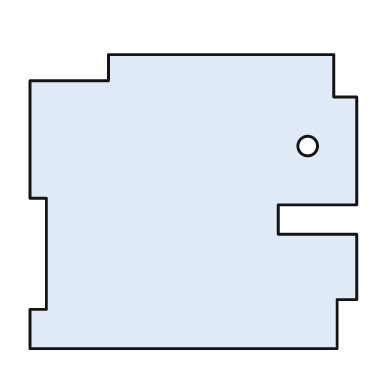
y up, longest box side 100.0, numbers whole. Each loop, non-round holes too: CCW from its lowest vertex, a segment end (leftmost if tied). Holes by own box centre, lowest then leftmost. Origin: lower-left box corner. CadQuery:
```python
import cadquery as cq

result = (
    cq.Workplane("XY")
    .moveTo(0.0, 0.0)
    .lineTo(94.0, 0.0)
    .lineTo(94.0, 15.0)
    .lineTo(100.0, 15.0)
    .lineTo(100.0, 35.0)
    .lineTo(76.0, 35.0)
    .lineTo(76.0, 44.0)
    .lineTo(100.0, 44.0)
    .lineTo(100.0, 77.0)
    .lineTo(93.0, 77.0)
    .lineTo(93.0, 90.0)
    .lineTo(24.0, 90.0)
    .lineTo(24.0, 82.0)
    .lineTo(0.0, 82.0)
    .lineTo(0.0, 46.0)
    .lineTo(5.0, 46.0)
    .lineTo(5.0, 12.0)
    .lineTo(0.0, 12.0)
    .close()
    .moveTo(85.0, 62.0)
    .circle(3.0)
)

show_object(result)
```